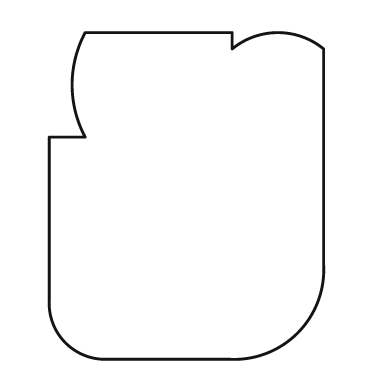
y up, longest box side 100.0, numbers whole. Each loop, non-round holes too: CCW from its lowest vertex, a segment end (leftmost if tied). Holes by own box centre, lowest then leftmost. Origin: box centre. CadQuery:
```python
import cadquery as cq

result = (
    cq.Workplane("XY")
    .moveTo(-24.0, -50.0)
    .lineTo(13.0, -50.0)
    .threePointArc((34.0, -42.0), (42.0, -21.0))
    .lineTo(42.0, 45.0)
    .threePointArc((28.0, 50.0), (14.0, 45.0))
    .lineTo(14.0, 50.0)
    .lineTo(-31.0, 50.0)
    .threePointArc((-35.0, 34.0), (-31.0, 18.0))
    .lineTo(-42.0, 18.0)
    .lineTo(-42.0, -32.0)
    .threePointArc((-37.0, -45.0), (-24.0, -50.0))
    .close()
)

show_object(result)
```